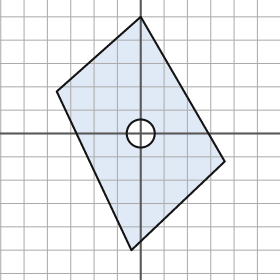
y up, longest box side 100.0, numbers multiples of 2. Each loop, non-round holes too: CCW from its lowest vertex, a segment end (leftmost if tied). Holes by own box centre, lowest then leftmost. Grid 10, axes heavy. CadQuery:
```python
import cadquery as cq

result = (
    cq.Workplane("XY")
    .moveTo(-4.0, -50.0)
    .lineTo(36.0, -12.0)
    .lineTo(0.0, 50.0)
    .lineTo(-36.0, 18.0)
    .close()
    .moveTo(0.0, 0.0)
    .circle(6.0)
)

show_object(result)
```